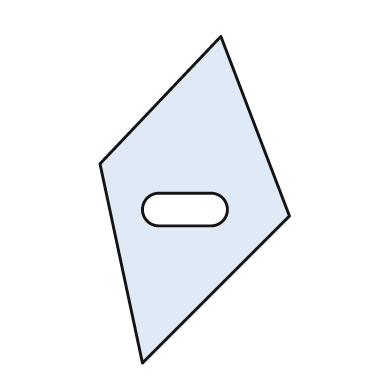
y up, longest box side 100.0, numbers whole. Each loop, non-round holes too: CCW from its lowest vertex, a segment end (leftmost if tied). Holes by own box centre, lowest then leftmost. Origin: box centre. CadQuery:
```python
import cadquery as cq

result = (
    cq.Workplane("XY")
    .moveTo(-16.0, -50.0)
    .lineTo(29.0, -5.0)
    .lineTo(8.0, 50.0)
    .lineTo(-29.0, 11.0)
    .close()
    .moveTo(-11.0, -8.0)
    .lineTo(5.0, -8.0)
    .threePointArc((10.0, -3.0), (5.0, 2.0))
    .lineTo(-11.0, 2.0)
    .threePointArc((-16.0, -3.0), (-11.0, -8.0))
    .close()
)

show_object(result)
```